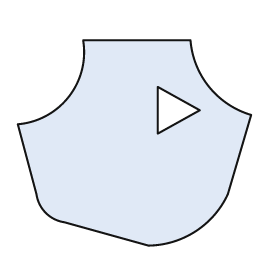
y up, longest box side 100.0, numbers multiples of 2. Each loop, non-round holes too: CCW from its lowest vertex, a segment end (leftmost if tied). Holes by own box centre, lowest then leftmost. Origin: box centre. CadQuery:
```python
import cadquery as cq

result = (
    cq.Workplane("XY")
    .moveTo(6.0, -44.0)
    .threePointArc((26.0, -38.0), (40.0, -22.0))
    .lineTo(50.0, 12.0)
    .threePointArc((32.0, 24.0), (24.0, 44.0))
    .lineTo(-22.0, 44.0)
    .threePointArc((-28.0, 20.0), (-50.0, 8.0))
    .lineTo(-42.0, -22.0)
    .threePointArc((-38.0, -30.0), (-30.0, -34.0))
    .close()
    .moveTo(10.0, 4.0)
    .lineTo(28.0, 14.0)
    .lineTo(10.0, 24.0)
    .close()
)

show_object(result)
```